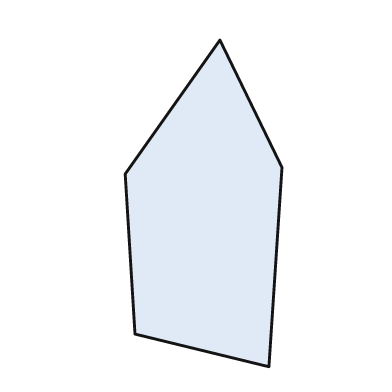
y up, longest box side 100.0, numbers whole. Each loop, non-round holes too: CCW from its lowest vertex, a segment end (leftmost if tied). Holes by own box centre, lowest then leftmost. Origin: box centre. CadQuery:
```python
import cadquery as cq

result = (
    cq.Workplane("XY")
    .moveTo(20.0, -50.0)
    .lineTo(24.0, 11.0)
    .lineTo(5.0, 50.0)
    .lineTo(-24.0, 9.0)
    .lineTo(-21.0, -40.0)
    .close()
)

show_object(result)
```